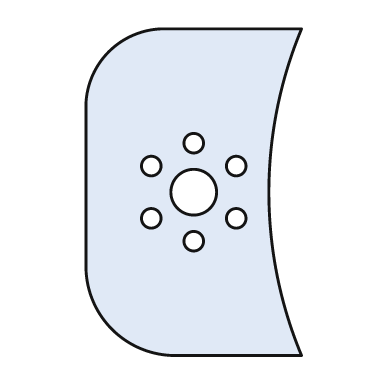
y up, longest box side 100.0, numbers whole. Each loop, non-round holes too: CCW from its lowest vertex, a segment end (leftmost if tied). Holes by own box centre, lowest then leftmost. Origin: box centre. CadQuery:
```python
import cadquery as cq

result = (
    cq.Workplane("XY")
    .moveTo(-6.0, -50.0)
    .lineTo(33.0, -50.0)
    .threePointArc((23.0, 0.0), (33.0, 50.0))
    .lineTo(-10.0, 50.0)
    .threePointArc((-26.0, 43.0), (-33.0, 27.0))
    .lineTo(-33.0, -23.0)
    .threePointArc((-25.0, -42.0), (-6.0, -50.0))
    .close()
    .moveTo(0.0, -15.0)
    .circle(3.0)
    .moveTo(-13.0, -8.0)
    .circle(3.0)
    .moveTo(13.0, -8.0)
    .circle(3.0)
    .moveTo(0.0, 0.0)
    .circle(7.0)
    .moveTo(-13.0, 8.0)
    .circle(3.0)
    .moveTo(13.0, 8.0)
    .circle(3.0)
    .moveTo(0.0, 15.0)
    .circle(3.0)
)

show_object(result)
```